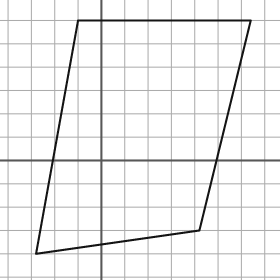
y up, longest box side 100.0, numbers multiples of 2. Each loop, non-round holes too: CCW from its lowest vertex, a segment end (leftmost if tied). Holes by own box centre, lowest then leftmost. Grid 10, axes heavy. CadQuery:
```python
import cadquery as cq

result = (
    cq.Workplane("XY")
    .moveTo(-28.0, -40.0)
    .lineTo(42.0, -30.0)
    .lineTo(64.0, 60.0)
    .lineTo(-10.0, 60.0)
    .close()
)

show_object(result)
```